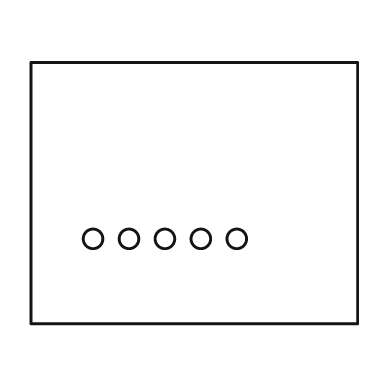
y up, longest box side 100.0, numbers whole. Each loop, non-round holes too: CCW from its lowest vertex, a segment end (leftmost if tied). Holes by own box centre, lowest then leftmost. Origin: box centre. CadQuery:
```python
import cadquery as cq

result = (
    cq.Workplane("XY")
    .moveTo(-50.0, -40.0)
    .lineTo(50.0, -40.0)
    .lineTo(50.0, 40.0)
    .lineTo(-50.0, 40.0)
    .close()
    .moveTo(-31.0, -14.0)
    .circle(3.0)
    .moveTo(-20.0, -14.0)
    .circle(3.0)
    .moveTo(-9.0, -14.0)
    .circle(3.0)
    .moveTo(2.0, -14.0)
    .circle(3.0)
    .moveTo(13.0, -14.0)
    .circle(3.0)
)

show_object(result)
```